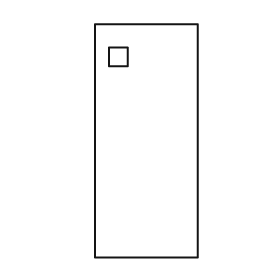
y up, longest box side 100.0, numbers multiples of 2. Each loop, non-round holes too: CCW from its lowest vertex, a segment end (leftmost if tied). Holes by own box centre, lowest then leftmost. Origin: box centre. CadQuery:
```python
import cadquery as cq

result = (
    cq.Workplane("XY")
    .moveTo(-22.0, -50.0)
    .lineTo(22.0, -50.0)
    .lineTo(22.0, 50.0)
    .lineTo(-22.0, 50.0)
    .close()
    .moveTo(-16.0, 32.0)
    .lineTo(-8.0, 32.0)
    .lineTo(-8.0, 40.0)
    .lineTo(-16.0, 40.0)
    .close()
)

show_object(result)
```